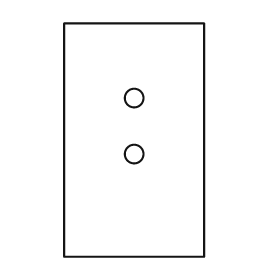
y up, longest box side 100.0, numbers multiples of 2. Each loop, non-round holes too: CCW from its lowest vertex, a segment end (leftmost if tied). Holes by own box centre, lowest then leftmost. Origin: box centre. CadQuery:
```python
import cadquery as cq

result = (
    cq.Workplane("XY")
    .moveTo(-30.0, -50.0)
    .lineTo(30.0, -50.0)
    .lineTo(30.0, 50.0)
    .lineTo(-30.0, 50.0)
    .close()
    .moveTo(0.0, -6.0)
    .circle(4.0)
    .moveTo(0.0, 18.0)
    .circle(4.0)
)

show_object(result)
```